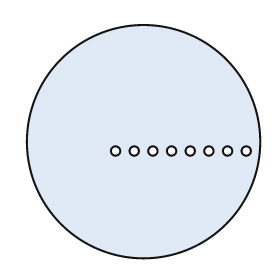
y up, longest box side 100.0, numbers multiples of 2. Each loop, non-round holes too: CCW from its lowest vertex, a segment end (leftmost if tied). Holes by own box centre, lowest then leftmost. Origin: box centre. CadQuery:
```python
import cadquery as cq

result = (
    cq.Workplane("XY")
    .moveTo(0.0, 0.0)
    .circle(50.0)
    .moveTo(-12.0, -4.0)
    .circle(2.0)
    .moveTo(-4.0, -4.0)
    .circle(2.0)
    .moveTo(4.0, -4.0)
    .circle(2.0)
    .moveTo(12.0, -4.0)
    .circle(2.0)
    .moveTo(20.0, -4.0)
    .circle(2.0)
    .moveTo(28.0, -4.0)
    .circle(2.0)
    .moveTo(36.0, -4.0)
    .circle(2.0)
    .moveTo(44.0, -4.0)
    .circle(2.0)
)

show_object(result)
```